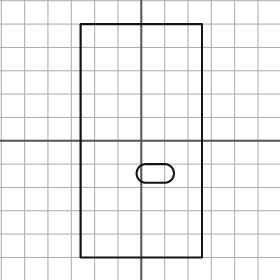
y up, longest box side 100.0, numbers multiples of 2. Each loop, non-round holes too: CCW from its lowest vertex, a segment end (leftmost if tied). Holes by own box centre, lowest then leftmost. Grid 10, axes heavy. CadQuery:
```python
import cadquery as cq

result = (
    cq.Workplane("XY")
    .moveTo(-26.0, -50.0)
    .lineTo(26.0, -50.0)
    .lineTo(26.0, 50.0)
    .lineTo(-26.0, 50.0)
    .close()
    .moveTo(2.0, -18.0)
    .lineTo(10.0, -18.0)
    .threePointArc((14.0, -14.0), (10.0, -10.0))
    .lineTo(2.0, -10.0)
    .threePointArc((-2.0, -14.0), (2.0, -18.0))
    .close()
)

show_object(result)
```